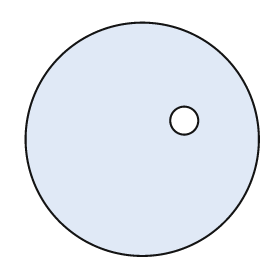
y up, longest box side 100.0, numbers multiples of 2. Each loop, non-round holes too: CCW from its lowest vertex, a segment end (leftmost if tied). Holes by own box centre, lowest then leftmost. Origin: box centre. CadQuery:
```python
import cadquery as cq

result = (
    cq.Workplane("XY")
    .moveTo(0.0, 0.0)
    .circle(50.0)
    .moveTo(18.0, 8.0)
    .circle(6.0)
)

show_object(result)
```